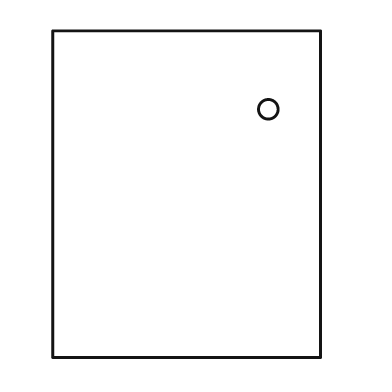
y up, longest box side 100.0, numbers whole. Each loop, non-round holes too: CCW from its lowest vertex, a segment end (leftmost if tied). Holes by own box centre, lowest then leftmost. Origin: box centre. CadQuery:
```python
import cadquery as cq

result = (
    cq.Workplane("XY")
    .moveTo(-41.0, -50.0)
    .lineTo(41.0, -50.0)
    .lineTo(41.0, 50.0)
    .lineTo(-41.0, 50.0)
    .close()
    .moveTo(25.0, 26.0)
    .circle(3.0)
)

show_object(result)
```